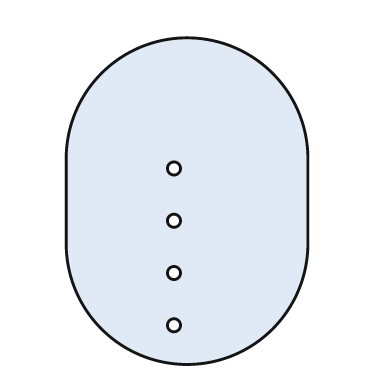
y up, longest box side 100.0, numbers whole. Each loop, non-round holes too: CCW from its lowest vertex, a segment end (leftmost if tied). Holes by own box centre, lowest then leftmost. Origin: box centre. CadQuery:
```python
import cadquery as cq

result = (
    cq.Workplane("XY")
    .moveTo(-37.0, -13.0)
    .threePointArc((0.0, -50.0), (37.0, -13.0))
    .lineTo(37.0, 13.0)
    .threePointArc((0.0, 50.0), (-37.0, 13.0))
    .close()
    .moveTo(-4.0, -38.0)
    .circle(2.0)
    .moveTo(-4.0, -22.0)
    .circle(2.0)
    .moveTo(-4.0, -6.0)
    .circle(2.0)
    .moveTo(-4.0, 10.0)
    .circle(2.0)
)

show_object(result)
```